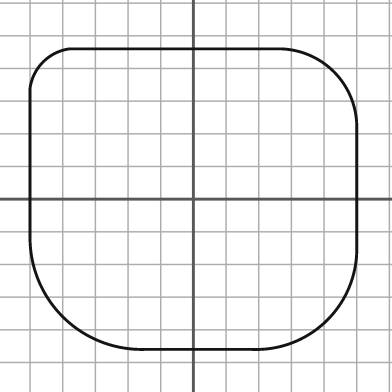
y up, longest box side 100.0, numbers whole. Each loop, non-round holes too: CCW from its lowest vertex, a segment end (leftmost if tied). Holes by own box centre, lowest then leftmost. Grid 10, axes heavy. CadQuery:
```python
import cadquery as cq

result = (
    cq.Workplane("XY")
    .moveTo(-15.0, -46.0)
    .lineTo(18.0, -46.0)
    .threePointArc((41.0, -37.0), (50.0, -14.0))
    .lineTo(50.0, 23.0)
    .threePointArc((43.0, 39.0), (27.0, 46.0))
    .lineTo(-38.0, 46.0)
    .threePointArc((-46.0, 42.0), (-50.0, 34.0))
    .lineTo(-50.0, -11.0)
    .threePointArc((-40.0, -36.0), (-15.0, -46.0))
    .close()
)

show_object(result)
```